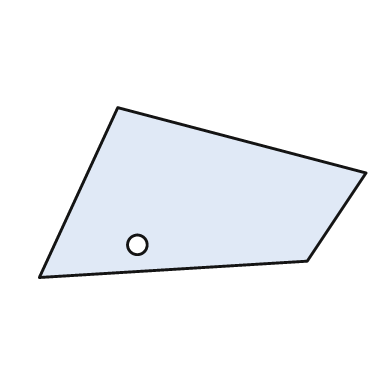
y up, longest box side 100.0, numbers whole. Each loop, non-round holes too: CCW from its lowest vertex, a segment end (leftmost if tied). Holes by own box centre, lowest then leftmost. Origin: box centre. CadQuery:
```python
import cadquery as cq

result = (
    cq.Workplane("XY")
    .moveTo(-50.0, -26.0)
    .lineTo(32.0, -21.0)
    .lineTo(50.0, 6.0)
    .lineTo(-26.0, 26.0)
    .close()
    .moveTo(-20.0, -16.0)
    .circle(3.0)
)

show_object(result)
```